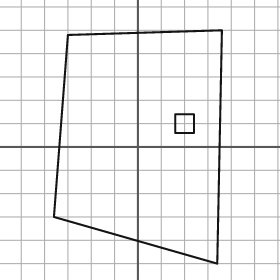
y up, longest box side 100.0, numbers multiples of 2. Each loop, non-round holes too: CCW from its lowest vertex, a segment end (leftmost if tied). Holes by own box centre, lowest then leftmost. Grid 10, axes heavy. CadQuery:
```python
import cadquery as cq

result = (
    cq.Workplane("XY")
    .moveTo(34.0, -50.0)
    .lineTo(36.0, 50.0)
    .lineTo(-30.0, 48.0)
    .lineTo(-36.0, -30.0)
    .close()
    .moveTo(16.0, 6.0)
    .lineTo(24.0, 6.0)
    .lineTo(24.0, 14.0)
    .lineTo(16.0, 14.0)
    .close()
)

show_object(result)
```